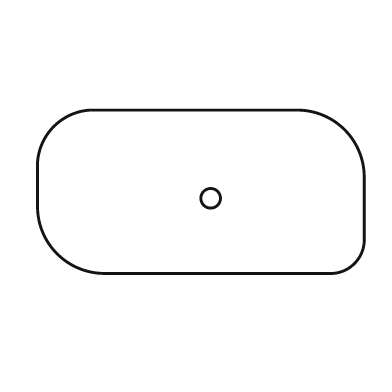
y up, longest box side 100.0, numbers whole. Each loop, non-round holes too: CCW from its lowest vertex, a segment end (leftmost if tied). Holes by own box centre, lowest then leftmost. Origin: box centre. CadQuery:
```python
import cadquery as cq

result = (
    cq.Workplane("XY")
    .moveTo(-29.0, -25.0)
    .lineTo(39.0, -25.0)
    .threePointArc((47.0, -22.0), (50.0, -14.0))
    .lineTo(50.0, 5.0)
    .threePointArc((44.0, 19.0), (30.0, 25.0))
    .lineTo(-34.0, 25.0)
    .threePointArc((-45.0, 20.0), (-50.0, 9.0))
    .lineTo(-50.0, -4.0)
    .threePointArc((-44.0, -19.0), (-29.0, -25.0))
    .close()
    .moveTo(3.0, -2.0)
    .circle(3.0)
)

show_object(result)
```